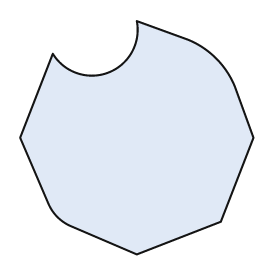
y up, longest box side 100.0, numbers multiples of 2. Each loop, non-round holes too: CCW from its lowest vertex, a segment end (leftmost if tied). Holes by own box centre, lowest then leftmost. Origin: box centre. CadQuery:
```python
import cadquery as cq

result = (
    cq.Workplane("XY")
    .moveTo(0.0, -50.0)
    .lineTo(36.0, -36.0)
    .lineTo(50.0, 0.0)
    .lineTo(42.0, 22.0)
    .threePointArc((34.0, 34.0), (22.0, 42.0))
    .lineTo(0.0, 50.0)
    .threePointArc((-12.0, 28.0), (-36.0, 36.0))
    .lineTo(-50.0, 0.0)
    .lineTo(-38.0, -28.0)
    .threePointArc((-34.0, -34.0), (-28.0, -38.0))
    .close()
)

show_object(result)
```